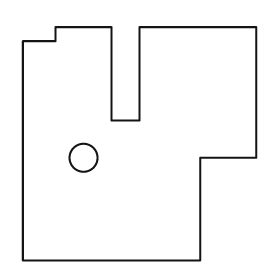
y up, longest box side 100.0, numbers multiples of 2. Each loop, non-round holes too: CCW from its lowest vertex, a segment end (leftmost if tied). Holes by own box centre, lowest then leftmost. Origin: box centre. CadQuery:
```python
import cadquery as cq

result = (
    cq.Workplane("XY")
    .moveTo(-50.0, -50.0)
    .lineTo(26.0, -50.0)
    .lineTo(26.0, -6.0)
    .lineTo(50.0, -6.0)
    .lineTo(50.0, 50.0)
    .lineTo(0.0, 50.0)
    .lineTo(0.0, 10.0)
    .lineTo(-12.0, 10.0)
    .lineTo(-12.0, 50.0)
    .lineTo(-36.0, 50.0)
    .lineTo(-36.0, 44.0)
    .lineTo(-50.0, 44.0)
    .close()
    .moveTo(-24.0, -6.0)
    .circle(6.0)
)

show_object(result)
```